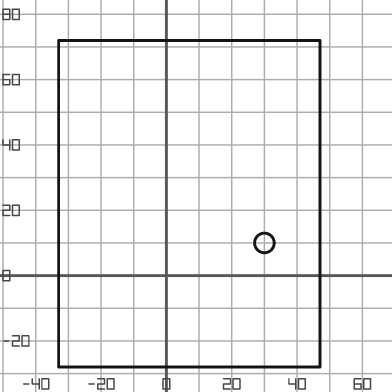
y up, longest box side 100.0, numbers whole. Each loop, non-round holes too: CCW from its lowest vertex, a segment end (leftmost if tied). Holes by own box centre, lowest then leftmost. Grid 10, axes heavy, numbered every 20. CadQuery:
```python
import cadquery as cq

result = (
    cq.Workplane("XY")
    .moveTo(-33.0, -28.0)
    .lineTo(47.0, -28.0)
    .lineTo(47.0, 72.0)
    .lineTo(-33.0, 72.0)
    .close()
    .moveTo(30.0, 10.0)
    .circle(3.0)
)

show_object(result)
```